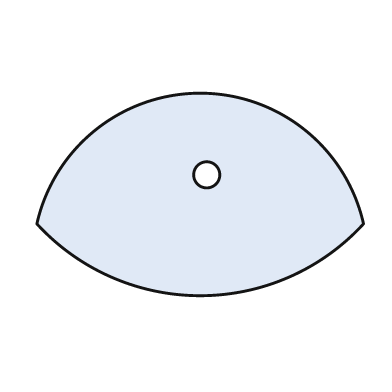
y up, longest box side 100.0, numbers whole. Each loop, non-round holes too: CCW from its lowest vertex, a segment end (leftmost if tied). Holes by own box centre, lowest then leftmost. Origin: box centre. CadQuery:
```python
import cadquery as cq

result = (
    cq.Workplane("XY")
    .moveTo(-50.0, -9.0)
    .threePointArc((0.0, -31.0), (50.0, -9.0))
    .threePointArc((0.0, 31.0), (-50.0, -9.0))
    .close()
    .moveTo(2.0, 6.0)
    .circle(4.0)
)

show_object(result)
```